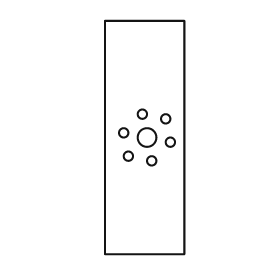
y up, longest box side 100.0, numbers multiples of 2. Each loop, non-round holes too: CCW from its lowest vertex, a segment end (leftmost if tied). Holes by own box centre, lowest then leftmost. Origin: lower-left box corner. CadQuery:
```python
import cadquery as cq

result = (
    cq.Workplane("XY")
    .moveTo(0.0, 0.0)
    .lineTo(34.0, 0.0)
    .lineTo(34.0, 100.0)
    .lineTo(0.0, 100.0)
    .close()
    .moveTo(20.0, 40.0)
    .circle(2.0)
    .moveTo(10.0, 42.0)
    .circle(2.0)
    .moveTo(28.0, 48.0)
    .circle(2.0)
    .moveTo(18.0, 50.0)
    .circle(4.0)
    .moveTo(8.0, 52.0)
    .circle(2.0)
    .moveTo(26.0, 58.0)
    .circle(2.0)
    .moveTo(16.0, 60.0)
    .circle(2.0)
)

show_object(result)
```